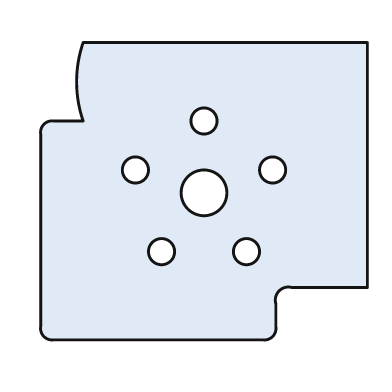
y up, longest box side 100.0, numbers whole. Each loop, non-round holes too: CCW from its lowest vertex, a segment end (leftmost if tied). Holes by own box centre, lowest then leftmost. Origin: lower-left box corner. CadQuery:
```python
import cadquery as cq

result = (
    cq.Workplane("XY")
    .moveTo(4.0, 0.0)
    .lineTo(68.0, 0.0)
    .threePointArc((71.0, 1.0), (72.0, 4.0))
    .lineTo(72.0, 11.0)
    .threePointArc((73.0, 15.0), (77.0, 16.0))
    .lineTo(100.0, 16.0)
    .lineTo(100.0, 91.0)
    .lineTo(13.0, 91.0)
    .threePointArc((11.0, 79.0), (13.0, 67.0))
    .lineTo(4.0, 67.0)
    .threePointArc((1.0, 66.0), (0.0, 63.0))
    .lineTo(0.0, 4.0)
    .threePointArc((1.0, 1.0), (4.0, 0.0))
    .close()
    .moveTo(37.0, 27.0)
    .circle(4.0)
    .moveTo(63.0, 27.0)
    .circle(4.0)
    .moveTo(50.0, 45.0)
    .circle(7.0)
    .moveTo(29.0, 52.0)
    .circle(4.0)
    .moveTo(71.0, 52.0)
    .circle(4.0)
    .moveTo(50.0, 67.0)
    .circle(4.0)
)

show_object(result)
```